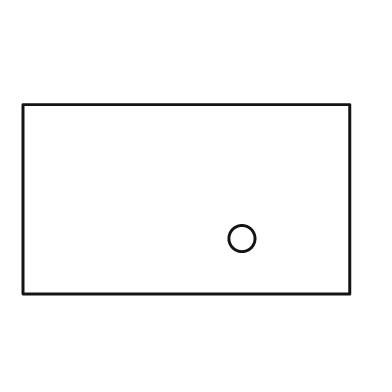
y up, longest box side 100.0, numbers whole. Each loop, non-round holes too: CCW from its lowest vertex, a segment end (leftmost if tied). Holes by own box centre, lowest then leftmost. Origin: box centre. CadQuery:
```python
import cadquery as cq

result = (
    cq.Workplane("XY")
    .moveTo(-50.0, -29.0)
    .lineTo(50.0, -29.0)
    .lineTo(50.0, 29.0)
    .lineTo(-50.0, 29.0)
    .close()
    .moveTo(17.0, -12.0)
    .circle(4.0)
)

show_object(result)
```